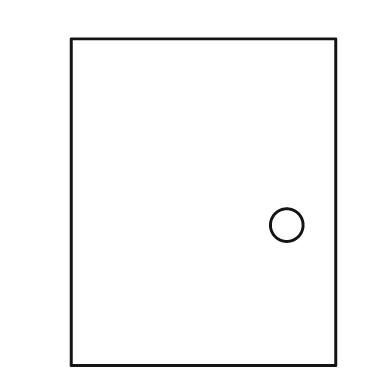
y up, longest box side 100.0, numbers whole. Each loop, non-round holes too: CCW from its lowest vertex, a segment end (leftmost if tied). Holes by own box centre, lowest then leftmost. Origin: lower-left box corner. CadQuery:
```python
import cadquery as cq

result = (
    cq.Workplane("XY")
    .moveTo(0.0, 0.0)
    .lineTo(81.0, 0.0)
    .lineTo(81.0, 100.0)
    .lineTo(0.0, 100.0)
    .close()
    .moveTo(66.0, 43.0)
    .circle(5.0)
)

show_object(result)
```